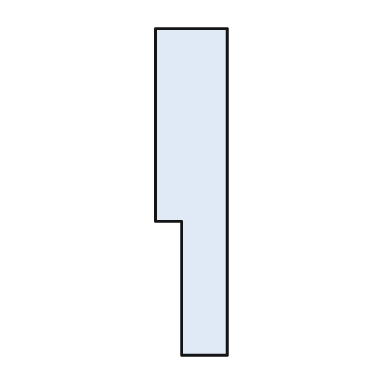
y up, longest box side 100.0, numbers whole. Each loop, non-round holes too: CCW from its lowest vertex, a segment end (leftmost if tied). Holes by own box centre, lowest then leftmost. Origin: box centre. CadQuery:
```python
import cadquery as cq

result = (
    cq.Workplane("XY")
    .moveTo(-3.0, -50.0)
    .lineTo(11.0, -50.0)
    .lineTo(11.0, 50.0)
    .lineTo(-11.0, 50.0)
    .lineTo(-11.0, -9.0)
    .lineTo(-3.0, -9.0)
    .close()
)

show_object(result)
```